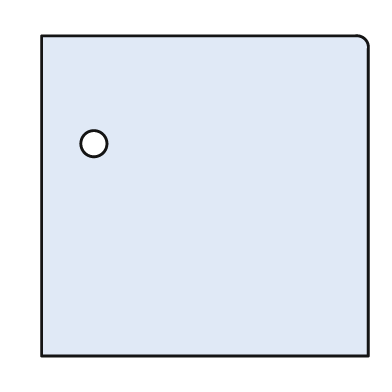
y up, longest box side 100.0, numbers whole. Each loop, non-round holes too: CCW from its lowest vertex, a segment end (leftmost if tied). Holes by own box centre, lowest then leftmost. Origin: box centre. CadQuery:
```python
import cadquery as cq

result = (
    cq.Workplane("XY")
    .moveTo(-50.0, -49.0)
    .lineTo(50.0, -49.0)
    .lineTo(50.0, 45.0)
    .threePointArc((49.0, 48.0), (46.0, 49.0))
    .lineTo(-50.0, 49.0)
    .close()
    .moveTo(-34.0, 16.0)
    .circle(4.0)
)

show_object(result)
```